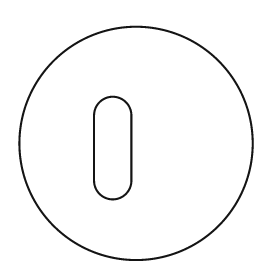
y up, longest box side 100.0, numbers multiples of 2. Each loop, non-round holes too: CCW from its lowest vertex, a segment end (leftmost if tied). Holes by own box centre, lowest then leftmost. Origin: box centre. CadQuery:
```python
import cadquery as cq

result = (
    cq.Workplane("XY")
    .moveTo(0.0, 0.0)
    .circle(50.0)
    .moveTo(-18.0, -16.0)
    .threePointArc((-10.0, -24.0), (-2.0, -16.0))
    .lineTo(-2.0, 12.0)
    .threePointArc((-10.0, 20.0), (-18.0, 12.0))
    .close()
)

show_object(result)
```